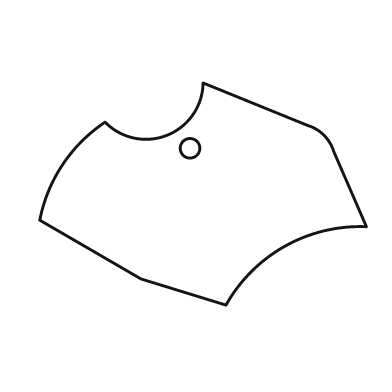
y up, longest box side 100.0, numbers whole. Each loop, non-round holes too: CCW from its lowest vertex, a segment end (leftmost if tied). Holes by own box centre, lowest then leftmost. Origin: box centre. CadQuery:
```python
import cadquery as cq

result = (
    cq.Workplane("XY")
    .moveTo(7.0, -34.0)
    .threePointArc((25.0, -16.0), (50.0, -10.0))
    .lineTo(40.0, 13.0)
    .threePointArc((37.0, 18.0), (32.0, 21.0))
    .lineTo(0.0, 34.0)
    .threePointArc((-11.0, 18.0), (-30.0, 22.0))
    .threePointArc((-43.0, 9.0), (-50.0, -8.0))
    .lineTo(-19.0, -26.0)
    .close()
    .moveTo(-4.0, 14.0)
    .circle(3.0)
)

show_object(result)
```